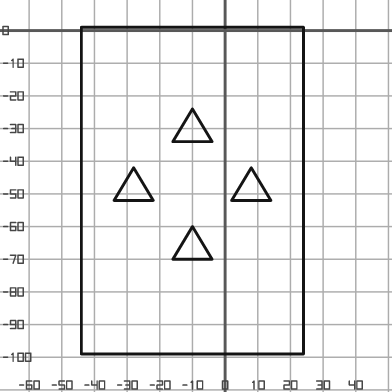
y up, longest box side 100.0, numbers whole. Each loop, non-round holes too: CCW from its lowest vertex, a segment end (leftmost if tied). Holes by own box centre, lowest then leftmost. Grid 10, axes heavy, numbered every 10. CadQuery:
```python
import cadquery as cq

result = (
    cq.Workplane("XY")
    .moveTo(-44.0, -99.0)
    .lineTo(24.0, -99.0)
    .lineTo(24.0, 1.0)
    .lineTo(-44.0, 1.0)
    .close()
    .moveTo(-16.0, -70.0)
    .lineTo(-4.0, -70.0)
    .lineTo(-10.0, -60.0)
    .close()
    .moveTo(-34.0, -52.0)
    .lineTo(-22.0, -52.0)
    .lineTo(-28.0, -42.0)
    .close()
    .moveTo(2.0, -52.0)
    .lineTo(14.0, -52.0)
    .lineTo(8.0, -42.0)
    .close()
    .moveTo(-16.0, -34.0)
    .lineTo(-4.0, -34.0)
    .lineTo(-10.0, -24.0)
    .close()
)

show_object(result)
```